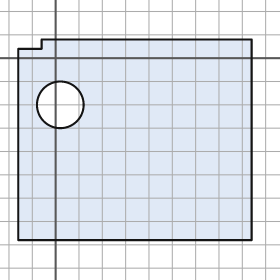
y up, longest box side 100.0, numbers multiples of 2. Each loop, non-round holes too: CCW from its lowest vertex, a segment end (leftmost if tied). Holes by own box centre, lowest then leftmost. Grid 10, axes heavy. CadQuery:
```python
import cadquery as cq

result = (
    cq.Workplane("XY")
    .moveTo(-16.0, -78.0)
    .lineTo(84.0, -78.0)
    .lineTo(84.0, 8.0)
    .lineTo(-6.0, 8.0)
    .lineTo(-6.0, 4.0)
    .lineTo(-16.0, 4.0)
    .close()
    .moveTo(2.0, -20.0)
    .circle(10.0)
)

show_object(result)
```